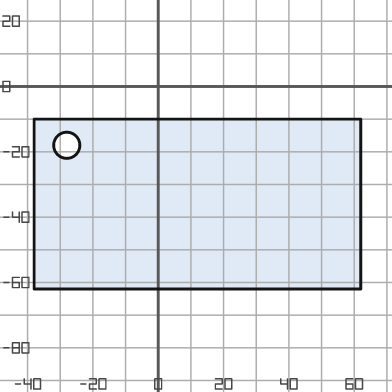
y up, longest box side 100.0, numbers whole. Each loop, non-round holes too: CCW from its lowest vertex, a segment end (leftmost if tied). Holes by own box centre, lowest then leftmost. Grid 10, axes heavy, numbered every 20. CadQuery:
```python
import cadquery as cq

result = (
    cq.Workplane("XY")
    .moveTo(-38.0, -62.0)
    .lineTo(62.0, -62.0)
    .lineTo(62.0, -10.0)
    .lineTo(-38.0, -10.0)
    .close()
    .moveTo(-28.0, -18.0)
    .circle(4.0)
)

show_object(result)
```